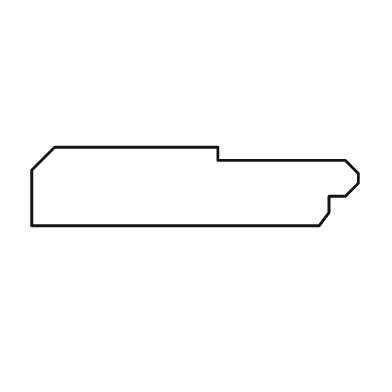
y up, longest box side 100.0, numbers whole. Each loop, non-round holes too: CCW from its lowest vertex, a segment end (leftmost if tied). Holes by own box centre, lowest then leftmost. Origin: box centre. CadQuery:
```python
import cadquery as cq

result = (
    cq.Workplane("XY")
    .moveTo(-50.0, -12.0)
    .lineTo(38.0, -12.0)
    .lineTo(41.0, -8.0)
    .lineTo(41.0, -3.0)
    .lineTo(46.0, -3.0)
    .lineTo(50.0, 1.0)
    .lineTo(50.0, 4.0)
    .lineTo(46.0, 8.0)
    .lineTo(7.0, 8.0)
    .lineTo(7.0, 12.0)
    .lineTo(-43.0, 12.0)
    .lineTo(-50.0, 5.0)
    .close()
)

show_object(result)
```